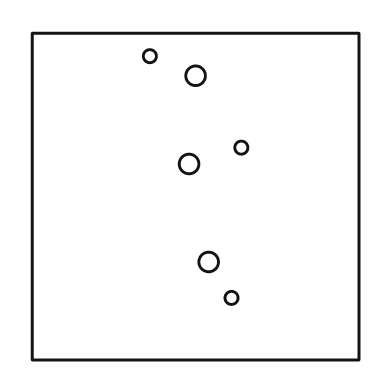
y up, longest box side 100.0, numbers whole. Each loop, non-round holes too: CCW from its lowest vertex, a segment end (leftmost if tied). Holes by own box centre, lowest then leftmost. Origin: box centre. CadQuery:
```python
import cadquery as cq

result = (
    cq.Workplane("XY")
    .moveTo(-50.0, -50.0)
    .lineTo(50.0, -50.0)
    .lineTo(50.0, 50.0)
    .lineTo(-50.0, 50.0)
    .close()
    .moveTo(11.0, -31.0)
    .circle(2.0)
    .moveTo(4.0, -20.0)
    .circle(3.0)
    .moveTo(-2.0, 10.0)
    .circle(3.0)
    .moveTo(14.0, 15.0)
    .circle(2.0)
    .moveTo(0.0, 37.0)
    .circle(3.0)
    .moveTo(-14.0, 43.0)
    .circle(2.0)
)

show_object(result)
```